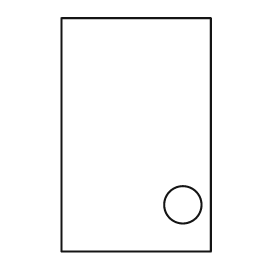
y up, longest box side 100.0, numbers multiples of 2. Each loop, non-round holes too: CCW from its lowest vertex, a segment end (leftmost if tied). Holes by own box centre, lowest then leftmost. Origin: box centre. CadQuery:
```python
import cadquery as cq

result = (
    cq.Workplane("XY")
    .moveTo(-32.0, -50.0)
    .lineTo(32.0, -50.0)
    .lineTo(32.0, 50.0)
    .lineTo(-32.0, 50.0)
    .close()
    .moveTo(20.0, -30.0)
    .circle(8.0)
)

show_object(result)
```